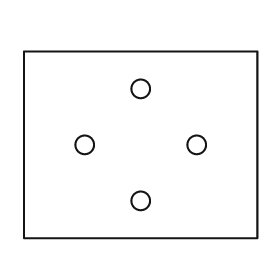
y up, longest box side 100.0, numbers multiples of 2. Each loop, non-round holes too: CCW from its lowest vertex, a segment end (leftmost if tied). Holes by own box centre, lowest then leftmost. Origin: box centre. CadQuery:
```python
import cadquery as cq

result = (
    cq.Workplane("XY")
    .moveTo(-50.0, -40.0)
    .lineTo(50.0, -40.0)
    .lineTo(50.0, 40.0)
    .lineTo(-50.0, 40.0)
    .close()
    .moveTo(0.0, -24.0)
    .circle(4.0)
    .moveTo(-24.0, 0.0)
    .circle(4.0)
    .moveTo(24.0, 0.0)
    .circle(4.0)
    .moveTo(0.0, 24.0)
    .circle(4.0)
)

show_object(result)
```